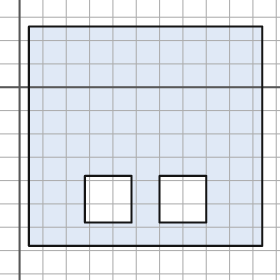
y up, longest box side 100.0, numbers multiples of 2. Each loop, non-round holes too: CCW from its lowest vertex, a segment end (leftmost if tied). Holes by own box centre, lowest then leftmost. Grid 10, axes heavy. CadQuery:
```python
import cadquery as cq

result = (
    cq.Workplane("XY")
    .moveTo(4.0, -68.0)
    .lineTo(104.0, -68.0)
    .lineTo(104.0, 26.0)
    .lineTo(4.0, 26.0)
    .close()
    .moveTo(28.0, -58.0)
    .lineTo(48.0, -58.0)
    .lineTo(48.0, -38.0)
    .lineTo(28.0, -38.0)
    .close()
    .moveTo(60.0, -58.0)
    .lineTo(80.0, -58.0)
    .lineTo(80.0, -38.0)
    .lineTo(60.0, -38.0)
    .close()
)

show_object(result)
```